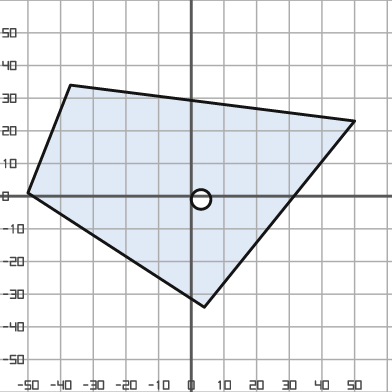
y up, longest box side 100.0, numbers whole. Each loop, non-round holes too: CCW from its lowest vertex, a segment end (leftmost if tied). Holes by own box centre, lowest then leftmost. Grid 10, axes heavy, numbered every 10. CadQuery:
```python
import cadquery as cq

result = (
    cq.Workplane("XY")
    .moveTo(4.0, -34.0)
    .lineTo(50.0, 23.0)
    .lineTo(-37.0, 34.0)
    .lineTo(-50.0, 1.0)
    .close()
    .moveTo(3.0, -1.0)
    .circle(3.0)
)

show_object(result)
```